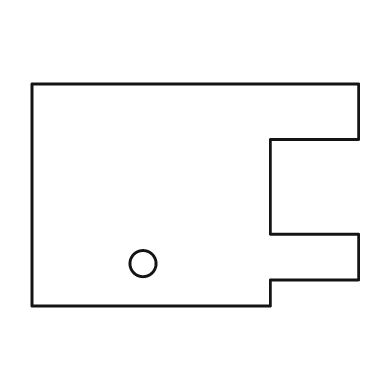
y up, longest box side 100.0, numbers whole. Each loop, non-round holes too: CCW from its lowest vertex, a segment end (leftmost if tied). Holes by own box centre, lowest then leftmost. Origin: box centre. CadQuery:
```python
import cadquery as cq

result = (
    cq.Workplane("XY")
    .moveTo(-50.0, -34.0)
    .lineTo(23.0, -34.0)
    .lineTo(23.0, -26.0)
    .lineTo(50.0, -26.0)
    .lineTo(50.0, -12.0)
    .lineTo(23.0, -12.0)
    .lineTo(23.0, 17.0)
    .lineTo(50.0, 17.0)
    .lineTo(50.0, 34.0)
    .lineTo(-50.0, 34.0)
    .close()
    .moveTo(-16.0, -21.0)
    .circle(4.0)
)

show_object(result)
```